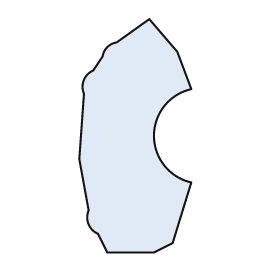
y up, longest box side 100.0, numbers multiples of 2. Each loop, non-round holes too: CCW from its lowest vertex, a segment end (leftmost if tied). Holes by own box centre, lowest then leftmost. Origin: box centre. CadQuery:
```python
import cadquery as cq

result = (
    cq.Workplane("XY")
    .moveTo(-12.0, -50.0)
    .lineTo(8.0, -50.0)
    .lineTo(16.0, -46.0)
    .lineTo(24.0, -20.0)
    .threePointArc((8.0, 0.0), (24.0, 20.0))
    .lineTo(18.0, 36.0)
    .lineTo(6.0, 50.0)
    .lineTo(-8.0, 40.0)
    .threePointArc((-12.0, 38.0), (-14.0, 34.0))
    .lineTo(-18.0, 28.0)
    .threePointArc((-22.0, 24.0), (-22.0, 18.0))
    .lineTo(-24.0, -10.0)
    .lineTo(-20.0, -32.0)
    .threePointArc((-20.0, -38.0), (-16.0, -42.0))
    .close()
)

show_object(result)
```